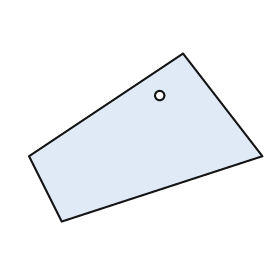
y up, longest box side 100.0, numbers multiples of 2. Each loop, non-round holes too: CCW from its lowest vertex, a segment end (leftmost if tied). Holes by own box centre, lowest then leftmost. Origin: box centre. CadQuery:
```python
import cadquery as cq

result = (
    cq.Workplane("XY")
    .moveTo(-36.0, -36.0)
    .lineTo(50.0, -8.0)
    .lineTo(16.0, 36.0)
    .lineTo(-50.0, -8.0)
    .close()
    .moveTo(6.0, 18.0)
    .circle(2.0)
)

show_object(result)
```